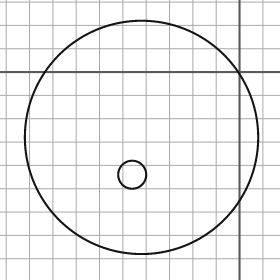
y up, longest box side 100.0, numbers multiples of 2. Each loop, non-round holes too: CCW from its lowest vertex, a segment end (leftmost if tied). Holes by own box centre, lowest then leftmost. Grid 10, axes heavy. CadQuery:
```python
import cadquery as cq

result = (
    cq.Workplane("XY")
    .moveTo(-42.0, -28.0)
    .circle(50.0)
    .moveTo(-46.0, -44.0)
    .circle(6.0)
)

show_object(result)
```